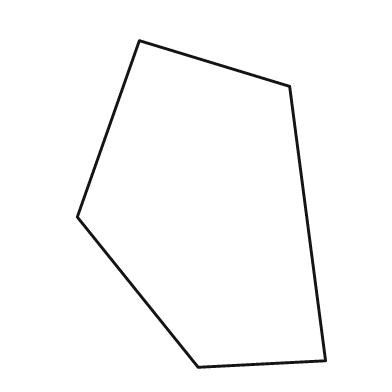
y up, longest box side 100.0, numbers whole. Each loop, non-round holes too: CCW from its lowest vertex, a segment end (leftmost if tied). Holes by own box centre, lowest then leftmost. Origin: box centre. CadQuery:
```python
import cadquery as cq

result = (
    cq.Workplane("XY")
    .moveTo(-1.0, -50.0)
    .lineTo(38.0, -48.0)
    .lineTo(27.0, 36.0)
    .lineTo(-19.0, 50.0)
    .lineTo(-38.0, -4.0)
    .close()
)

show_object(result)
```